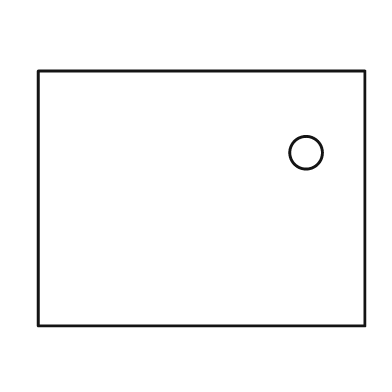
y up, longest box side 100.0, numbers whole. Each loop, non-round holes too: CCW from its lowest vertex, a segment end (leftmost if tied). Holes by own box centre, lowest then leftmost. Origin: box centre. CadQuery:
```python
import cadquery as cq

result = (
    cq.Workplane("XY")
    .moveTo(-50.0, -39.0)
    .lineTo(50.0, -39.0)
    .lineTo(50.0, 39.0)
    .lineTo(-50.0, 39.0)
    .close()
    .moveTo(32.0, 14.0)
    .circle(5.0)
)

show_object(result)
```